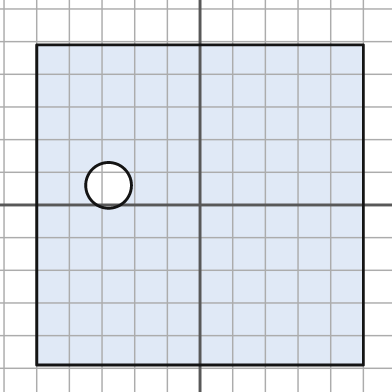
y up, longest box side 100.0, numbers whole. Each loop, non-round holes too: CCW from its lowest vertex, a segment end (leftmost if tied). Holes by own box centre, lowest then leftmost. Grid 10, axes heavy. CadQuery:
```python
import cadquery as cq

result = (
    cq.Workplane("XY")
    .moveTo(-50.0, -49.0)
    .lineTo(50.0, -49.0)
    .lineTo(50.0, 49.0)
    .lineTo(-50.0, 49.0)
    .close()
    .moveTo(-28.0, 6.0)
    .circle(7.0)
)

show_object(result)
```